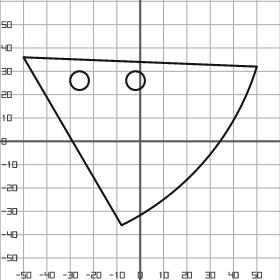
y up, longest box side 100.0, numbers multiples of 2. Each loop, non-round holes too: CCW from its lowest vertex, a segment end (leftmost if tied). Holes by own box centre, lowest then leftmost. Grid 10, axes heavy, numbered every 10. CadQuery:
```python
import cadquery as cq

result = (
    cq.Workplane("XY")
    .moveTo(-8.0, -36.0)
    .threePointArc((28.0, -8.0), (50.0, 32.0))
    .lineTo(-50.0, 36.0)
    .close()
    .moveTo(-26.0, 26.0)
    .circle(4.0)
    .moveTo(-2.0, 26.0)
    .circle(4.0)
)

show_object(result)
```